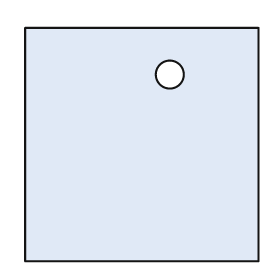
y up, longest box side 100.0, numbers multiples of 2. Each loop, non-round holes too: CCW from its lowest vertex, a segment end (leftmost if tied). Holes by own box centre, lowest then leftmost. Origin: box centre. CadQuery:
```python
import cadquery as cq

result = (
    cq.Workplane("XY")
    .moveTo(-50.0, -50.0)
    .lineTo(50.0, -50.0)
    .lineTo(50.0, 50.0)
    .lineTo(-50.0, 50.0)
    .close()
    .moveTo(12.0, 30.0)
    .circle(6.0)
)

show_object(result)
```